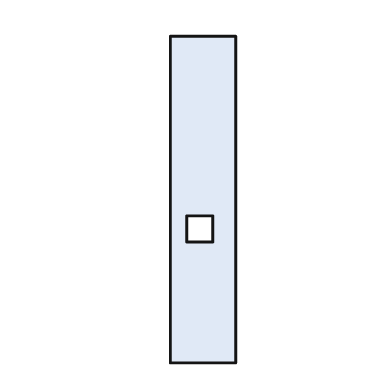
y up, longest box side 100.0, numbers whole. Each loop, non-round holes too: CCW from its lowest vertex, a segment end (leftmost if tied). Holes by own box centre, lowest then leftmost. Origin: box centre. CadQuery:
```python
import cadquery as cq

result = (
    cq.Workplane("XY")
    .moveTo(-10.0, -50.0)
    .lineTo(10.0, -50.0)
    .lineTo(10.0, 50.0)
    .lineTo(-10.0, 50.0)
    .close()
    .moveTo(-5.0, -13.0)
    .lineTo(3.0, -13.0)
    .lineTo(3.0, -5.0)
    .lineTo(-5.0, -5.0)
    .close()
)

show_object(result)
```